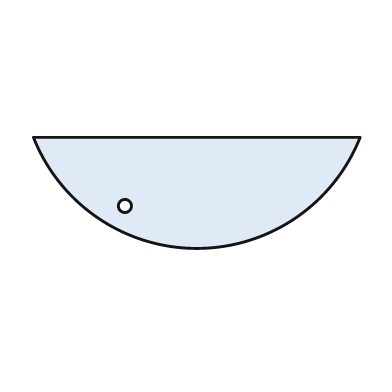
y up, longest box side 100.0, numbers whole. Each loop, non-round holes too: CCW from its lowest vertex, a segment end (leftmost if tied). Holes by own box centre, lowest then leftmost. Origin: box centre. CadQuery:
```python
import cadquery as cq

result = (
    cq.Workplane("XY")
    .moveTo(-50.0, 17.0)
    .threePointArc((0.0, -17.0), (50.0, 17.0))
    .close()
    .moveTo(-22.0, -4.0)
    .circle(2.0)
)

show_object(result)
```